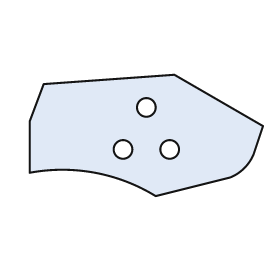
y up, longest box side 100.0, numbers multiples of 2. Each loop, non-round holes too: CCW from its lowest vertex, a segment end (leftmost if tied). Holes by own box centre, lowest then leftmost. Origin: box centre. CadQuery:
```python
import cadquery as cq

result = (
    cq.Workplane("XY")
    .moveTo(4.0, -26.0)
    .lineTo(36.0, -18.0)
    .threePointArc((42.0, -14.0), (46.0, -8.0))
    .lineTo(50.0, 4.0)
    .lineTo(12.0, 26.0)
    .lineTo(-44.0, 22.0)
    .lineTo(-50.0, 6.0)
    .lineTo(-50.0, -16.0)
    .threePointArc((-22.0, -16.0), (4.0, -26.0))
    .close()
    .moveTo(-10.0, -6.0)
    .circle(4.0)
    .moveTo(10.0, -6.0)
    .circle(4.0)
    .moveTo(0.0, 12.0)
    .circle(4.0)
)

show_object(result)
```